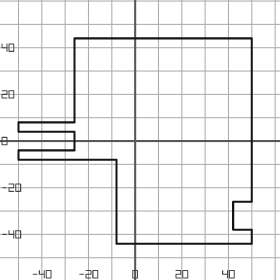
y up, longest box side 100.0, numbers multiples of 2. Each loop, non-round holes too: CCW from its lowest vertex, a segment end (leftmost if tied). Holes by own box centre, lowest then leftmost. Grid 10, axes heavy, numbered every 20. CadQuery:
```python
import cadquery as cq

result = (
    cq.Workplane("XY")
    .moveTo(-8.0, -44.0)
    .lineTo(50.0, -44.0)
    .lineTo(50.0, -38.0)
    .lineTo(42.0, -38.0)
    .lineTo(42.0, -26.0)
    .lineTo(50.0, -26.0)
    .lineTo(50.0, 44.0)
    .lineTo(-26.0, 44.0)
    .lineTo(-26.0, 8.0)
    .lineTo(-50.0, 8.0)
    .lineTo(-50.0, 4.0)
    .lineTo(-26.0, 4.0)
    .lineTo(-26.0, -4.0)
    .lineTo(-50.0, -4.0)
    .lineTo(-50.0, -8.0)
    .lineTo(-8.0, -8.0)
    .close()
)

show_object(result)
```